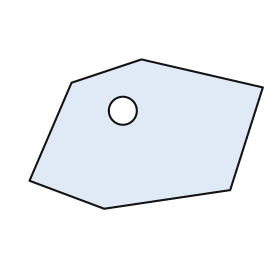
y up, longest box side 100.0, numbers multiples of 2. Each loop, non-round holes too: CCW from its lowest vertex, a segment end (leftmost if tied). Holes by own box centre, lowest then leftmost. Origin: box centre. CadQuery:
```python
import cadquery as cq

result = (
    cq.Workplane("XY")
    .moveTo(-18.0, -32.0)
    .lineTo(36.0, -24.0)
    .lineTo(50.0, 20.0)
    .lineTo(-2.0, 32.0)
    .lineTo(-32.0, 22.0)
    .lineTo(-50.0, -20.0)
    .close()
    .moveTo(-10.0, 10.0)
    .circle(6.0)
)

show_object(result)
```